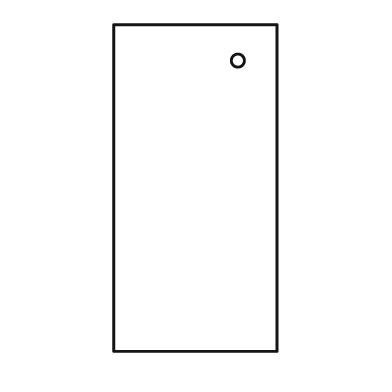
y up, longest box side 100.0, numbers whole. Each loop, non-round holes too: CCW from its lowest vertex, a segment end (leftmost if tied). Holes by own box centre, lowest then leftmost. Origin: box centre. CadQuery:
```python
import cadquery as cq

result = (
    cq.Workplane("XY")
    .moveTo(-25.0, -50.0)
    .lineTo(25.0, -50.0)
    .lineTo(25.0, 50.0)
    .lineTo(-25.0, 50.0)
    .close()
    .moveTo(13.0, 39.0)
    .circle(2.0)
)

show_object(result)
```